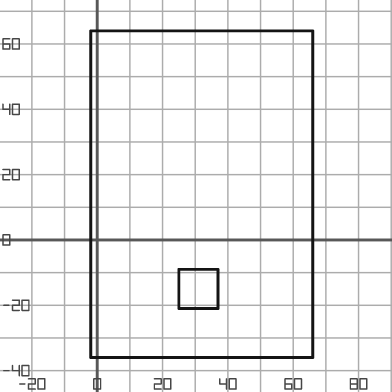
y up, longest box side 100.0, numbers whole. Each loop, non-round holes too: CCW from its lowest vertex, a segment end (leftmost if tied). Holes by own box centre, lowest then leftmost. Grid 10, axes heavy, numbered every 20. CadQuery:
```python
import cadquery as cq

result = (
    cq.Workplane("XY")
    .moveTo(-2.0, -36.0)
    .lineTo(66.0, -36.0)
    .lineTo(66.0, 64.0)
    .lineTo(-2.0, 64.0)
    .close()
    .moveTo(25.0, -21.0)
    .lineTo(37.0, -21.0)
    .lineTo(37.0, -9.0)
    .lineTo(25.0, -9.0)
    .close()
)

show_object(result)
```